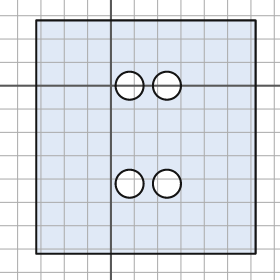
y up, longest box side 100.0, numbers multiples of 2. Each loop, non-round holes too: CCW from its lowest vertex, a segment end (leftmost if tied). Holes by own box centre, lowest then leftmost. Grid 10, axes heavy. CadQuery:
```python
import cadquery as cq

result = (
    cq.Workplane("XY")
    .moveTo(-32.0, -72.0)
    .lineTo(62.0, -72.0)
    .lineTo(62.0, 28.0)
    .lineTo(-32.0, 28.0)
    .close()
    .moveTo(8.0, -42.0)
    .circle(6.0)
    .moveTo(24.0, -42.0)
    .circle(6.0)
    .moveTo(8.0, 0.0)
    .circle(6.0)
    .moveTo(24.0, 0.0)
    .circle(6.0)
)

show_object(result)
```